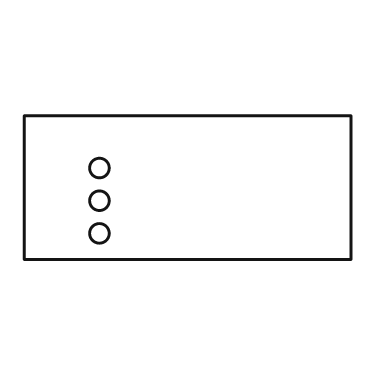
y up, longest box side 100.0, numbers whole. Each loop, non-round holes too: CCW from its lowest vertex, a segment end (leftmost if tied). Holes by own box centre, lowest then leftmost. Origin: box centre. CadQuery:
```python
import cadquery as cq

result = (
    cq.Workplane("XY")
    .moveTo(-50.0, -22.0)
    .lineTo(50.0, -22.0)
    .lineTo(50.0, 22.0)
    .lineTo(-50.0, 22.0)
    .close()
    .moveTo(-27.0, -14.0)
    .circle(3.0)
    .moveTo(-27.0, -4.0)
    .circle(3.0)
    .moveTo(-27.0, 6.0)
    .circle(3.0)
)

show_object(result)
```